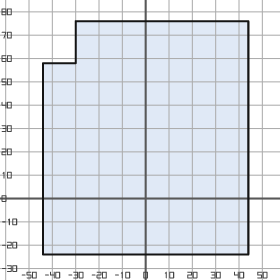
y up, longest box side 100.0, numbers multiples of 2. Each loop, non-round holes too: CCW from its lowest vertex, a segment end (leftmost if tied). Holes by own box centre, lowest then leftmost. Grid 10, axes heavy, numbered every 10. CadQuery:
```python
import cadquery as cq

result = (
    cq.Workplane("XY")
    .moveTo(-44.0, -24.0)
    .lineTo(44.0, -24.0)
    .lineTo(44.0, 76.0)
    .lineTo(-30.0, 76.0)
    .lineTo(-30.0, 58.0)
    .lineTo(-44.0, 58.0)
    .close()
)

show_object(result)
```